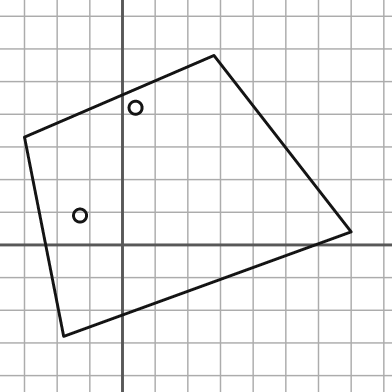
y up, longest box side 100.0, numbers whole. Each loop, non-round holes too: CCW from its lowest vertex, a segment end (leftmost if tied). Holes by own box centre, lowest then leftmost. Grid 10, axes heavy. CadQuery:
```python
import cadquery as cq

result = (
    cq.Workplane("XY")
    .moveTo(-18.0, -28.0)
    .lineTo(70.0, 4.0)
    .lineTo(28.0, 58.0)
    .lineTo(-30.0, 33.0)
    .close()
    .moveTo(-13.0, 9.0)
    .circle(2.0)
    .moveTo(4.0, 42.0)
    .circle(2.0)
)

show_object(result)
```